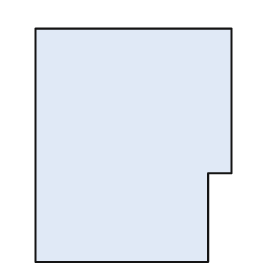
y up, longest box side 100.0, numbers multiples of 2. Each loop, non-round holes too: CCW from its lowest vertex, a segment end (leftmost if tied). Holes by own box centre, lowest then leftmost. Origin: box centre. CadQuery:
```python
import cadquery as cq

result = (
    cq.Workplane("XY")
    .moveTo(-42.0, -50.0)
    .lineTo(32.0, -50.0)
    .lineTo(32.0, -12.0)
    .lineTo(42.0, -12.0)
    .lineTo(42.0, 50.0)
    .lineTo(-42.0, 50.0)
    .close()
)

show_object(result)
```